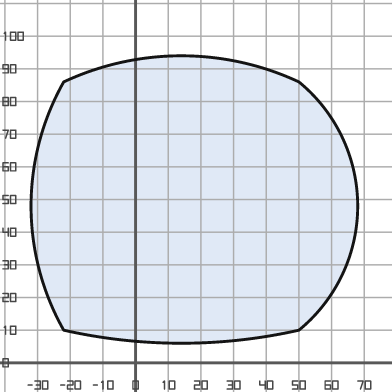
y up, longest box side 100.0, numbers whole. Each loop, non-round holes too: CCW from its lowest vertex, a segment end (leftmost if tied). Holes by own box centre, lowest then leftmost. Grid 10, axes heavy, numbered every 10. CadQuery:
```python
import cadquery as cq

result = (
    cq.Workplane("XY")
    .moveTo(-22.0, 10.0)
    .threePointArc((14.0, 6.0), (50.0, 10.0))
    .threePointArc((68.0, 48.0), (50.0, 86.0))
    .threePointArc((14.0, 94.0), (-22.0, 86.0))
    .threePointArc((-32.0, 48.0), (-22.0, 10.0))
    .close()
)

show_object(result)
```